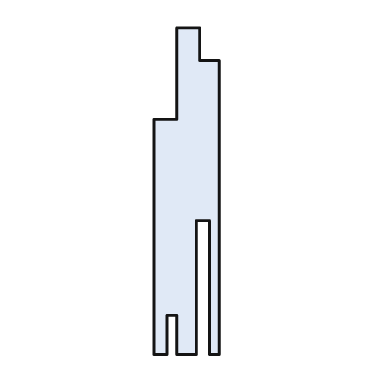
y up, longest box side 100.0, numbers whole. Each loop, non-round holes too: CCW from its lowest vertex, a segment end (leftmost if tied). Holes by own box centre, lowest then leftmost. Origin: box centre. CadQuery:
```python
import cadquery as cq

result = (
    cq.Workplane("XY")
    .moveTo(-10.0, -50.0)
    .lineTo(-6.0, -50.0)
    .lineTo(-6.0, -38.0)
    .lineTo(-3.0, -38.0)
    .lineTo(-3.0, -50.0)
    .lineTo(3.0, -50.0)
    .lineTo(3.0, -9.0)
    .lineTo(7.0, -9.0)
    .lineTo(7.0, -50.0)
    .lineTo(10.0, -50.0)
    .lineTo(10.0, 40.0)
    .lineTo(4.0, 40.0)
    .lineTo(4.0, 50.0)
    .lineTo(-3.0, 50.0)
    .lineTo(-3.0, 22.0)
    .lineTo(-10.0, 22.0)
    .close()
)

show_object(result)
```